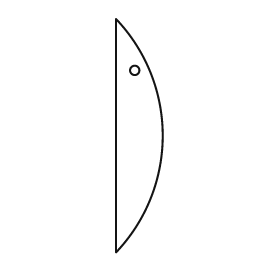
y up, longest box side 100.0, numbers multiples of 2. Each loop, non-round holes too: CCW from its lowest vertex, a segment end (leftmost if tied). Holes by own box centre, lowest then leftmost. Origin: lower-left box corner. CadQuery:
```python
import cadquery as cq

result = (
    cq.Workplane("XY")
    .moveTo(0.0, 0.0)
    .threePointArc((20.0, 50.0), (0.0, 100.0))
    .close()
    .moveTo(8.0, 78.0)
    .circle(2.0)
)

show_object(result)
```